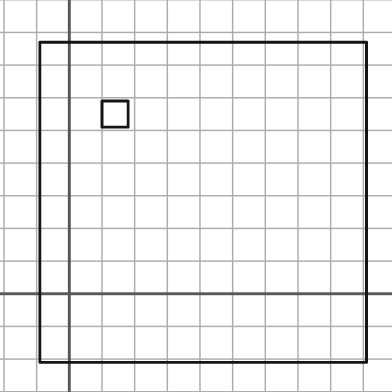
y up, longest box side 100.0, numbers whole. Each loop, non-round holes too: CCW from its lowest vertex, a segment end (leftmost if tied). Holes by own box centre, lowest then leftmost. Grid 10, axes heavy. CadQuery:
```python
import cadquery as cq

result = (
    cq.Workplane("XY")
    .moveTo(-9.0, -21.0)
    .lineTo(91.0, -21.0)
    .lineTo(91.0, 77.0)
    .lineTo(-9.0, 77.0)
    .close()
    .moveTo(10.0, 51.0)
    .lineTo(18.0, 51.0)
    .lineTo(18.0, 59.0)
    .lineTo(10.0, 59.0)
    .close()
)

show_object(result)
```